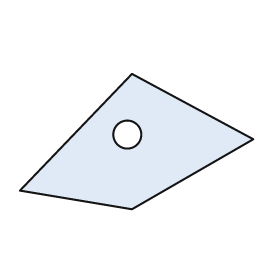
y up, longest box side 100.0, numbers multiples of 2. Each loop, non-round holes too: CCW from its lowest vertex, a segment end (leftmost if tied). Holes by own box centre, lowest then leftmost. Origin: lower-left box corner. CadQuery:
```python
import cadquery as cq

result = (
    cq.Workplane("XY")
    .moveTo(48.0, 0.0)
    .lineTo(100.0, 30.0)
    .lineTo(48.0, 58.0)
    .lineTo(0.0, 8.0)
    .close()
    .moveTo(46.0, 32.0)
    .circle(6.0)
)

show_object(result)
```